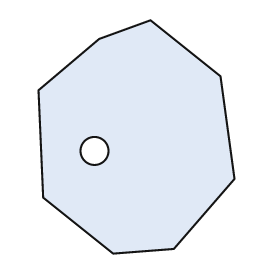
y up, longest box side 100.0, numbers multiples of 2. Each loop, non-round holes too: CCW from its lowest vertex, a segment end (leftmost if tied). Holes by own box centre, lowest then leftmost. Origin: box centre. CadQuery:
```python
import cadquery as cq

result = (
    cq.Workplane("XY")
    .moveTo(-10.0, -50.0)
    .lineTo(16.0, -48.0)
    .lineTo(42.0, -18.0)
    .lineTo(36.0, 26.0)
    .lineTo(6.0, 50.0)
    .lineTo(-16.0, 42.0)
    .lineTo(-42.0, 20.0)
    .lineTo(-40.0, -26.0)
    .close()
    .moveTo(-18.0, -6.0)
    .circle(6.0)
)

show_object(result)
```